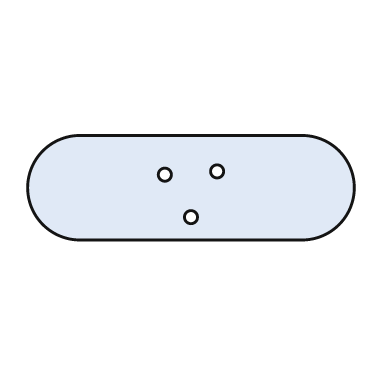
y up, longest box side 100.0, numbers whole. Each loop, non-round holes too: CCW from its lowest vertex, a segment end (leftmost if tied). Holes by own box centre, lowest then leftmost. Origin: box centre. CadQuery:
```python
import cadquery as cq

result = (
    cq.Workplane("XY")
    .moveTo(-34.0, -16.0)
    .lineTo(34.0, -16.0)
    .threePointArc((50.0, 0.0), (34.0, 16.0))
    .lineTo(-34.0, 16.0)
    .threePointArc((-50.0, 0.0), (-34.0, -16.0))
    .close()
    .moveTo(0.0, -9.0)
    .circle(2.0)
    .moveTo(-8.0, 4.0)
    .circle(2.0)
    .moveTo(8.0, 5.0)
    .circle(2.0)
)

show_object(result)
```